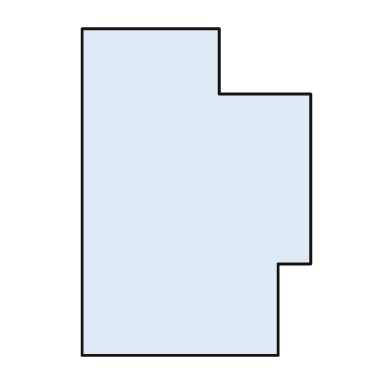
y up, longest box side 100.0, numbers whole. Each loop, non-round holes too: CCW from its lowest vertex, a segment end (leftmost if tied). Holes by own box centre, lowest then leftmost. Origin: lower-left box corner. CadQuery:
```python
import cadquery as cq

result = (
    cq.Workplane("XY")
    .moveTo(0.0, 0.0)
    .lineTo(60.0, 0.0)
    .lineTo(60.0, 28.0)
    .lineTo(70.0, 28.0)
    .lineTo(70.0, 80.0)
    .lineTo(42.0, 80.0)
    .lineTo(42.0, 100.0)
    .lineTo(0.0, 100.0)
    .close()
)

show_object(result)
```